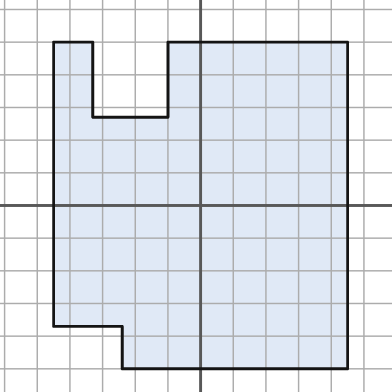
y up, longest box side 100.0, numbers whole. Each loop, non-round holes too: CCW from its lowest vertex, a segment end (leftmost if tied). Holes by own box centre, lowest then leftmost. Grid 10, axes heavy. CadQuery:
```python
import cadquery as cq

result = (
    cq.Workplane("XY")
    .moveTo(-24.0, -50.0)
    .lineTo(45.0, -50.0)
    .lineTo(45.0, 50.0)
    .lineTo(-10.0, 50.0)
    .lineTo(-10.0, 27.0)
    .lineTo(-33.0, 27.0)
    .lineTo(-33.0, 50.0)
    .lineTo(-45.0, 50.0)
    .lineTo(-45.0, -37.0)
    .lineTo(-24.0, -37.0)
    .close()
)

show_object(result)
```